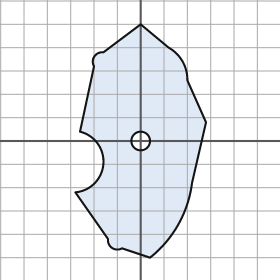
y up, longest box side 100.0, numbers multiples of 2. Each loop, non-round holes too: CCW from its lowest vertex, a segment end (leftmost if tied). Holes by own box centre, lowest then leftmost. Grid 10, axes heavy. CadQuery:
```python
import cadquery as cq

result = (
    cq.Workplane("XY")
    .moveTo(4.0, -50.0)
    .threePointArc((16.0, -36.0), (22.0, -18.0))
    .lineTo(28.0, 8.0)
    .lineTo(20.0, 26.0)
    .threePointArc((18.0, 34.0), (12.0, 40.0))
    .lineTo(0.0, 50.0)
    .lineTo(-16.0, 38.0)
    .threePointArc((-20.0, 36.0), (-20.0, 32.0))
    .lineTo(-26.0, 4.0)
    .threePointArc((-16.0, -10.0), (-28.0, -22.0))
    .lineTo(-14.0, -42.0)
    .threePointArc((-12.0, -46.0), (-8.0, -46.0))
    .close()
    .moveTo(0.0, 0.0)
    .circle(4.0)
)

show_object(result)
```